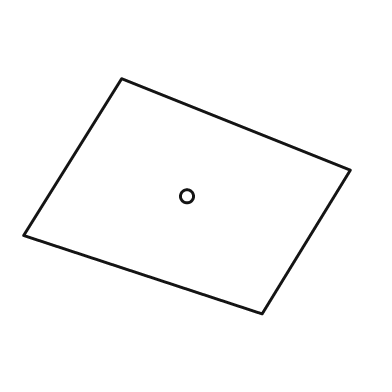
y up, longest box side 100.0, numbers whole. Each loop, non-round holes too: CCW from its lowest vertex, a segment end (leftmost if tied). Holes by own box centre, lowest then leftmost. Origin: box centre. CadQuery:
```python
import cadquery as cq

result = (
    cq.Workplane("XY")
    .moveTo(23.0, -36.0)
    .lineTo(50.0, 8.0)
    .lineTo(-20.0, 36.0)
    .lineTo(-50.0, -12.0)
    .close()
    .moveTo(0.0, 0.0)
    .circle(2.0)
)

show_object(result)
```